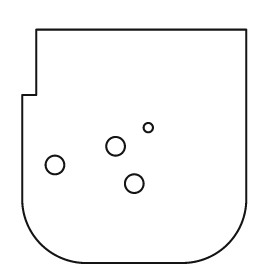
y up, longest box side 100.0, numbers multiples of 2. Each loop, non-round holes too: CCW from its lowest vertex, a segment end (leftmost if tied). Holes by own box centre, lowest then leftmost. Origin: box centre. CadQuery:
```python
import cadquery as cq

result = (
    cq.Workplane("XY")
    .moveTo(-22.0, -50.0)
    .lineTo(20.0, -50.0)
    .threePointArc((40.0, -42.0), (48.0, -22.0))
    .lineTo(48.0, 50.0)
    .lineTo(-42.0, 50.0)
    .lineTo(-42.0, 22.0)
    .lineTo(-48.0, 22.0)
    .lineTo(-48.0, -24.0)
    .threePointArc((-40.0, -42.0), (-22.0, -50.0))
    .close()
    .moveTo(0.0, -16.0)
    .circle(4.0)
    .moveTo(-34.0, -8.0)
    .circle(4.0)
    .moveTo(-8.0, 0.0)
    .circle(4.0)
    .moveTo(6.0, 8.0)
    .circle(2.0)
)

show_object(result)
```